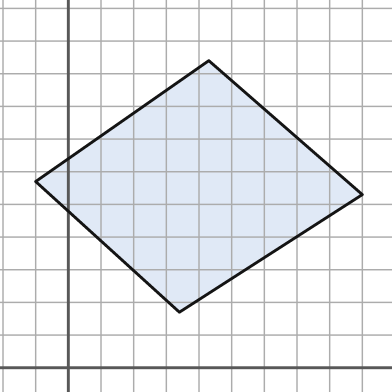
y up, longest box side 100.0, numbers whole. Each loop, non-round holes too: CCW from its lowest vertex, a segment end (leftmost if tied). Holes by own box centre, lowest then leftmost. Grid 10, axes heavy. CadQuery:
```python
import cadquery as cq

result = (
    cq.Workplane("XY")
    .moveTo(34.0, 17.0)
    .lineTo(90.0, 53.0)
    .lineTo(43.0, 94.0)
    .lineTo(-10.0, 57.0)
    .close()
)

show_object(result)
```